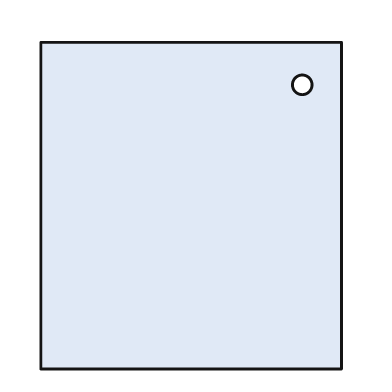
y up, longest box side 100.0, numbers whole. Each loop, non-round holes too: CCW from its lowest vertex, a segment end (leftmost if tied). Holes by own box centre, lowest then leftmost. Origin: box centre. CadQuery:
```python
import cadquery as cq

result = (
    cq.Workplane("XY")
    .moveTo(-46.0, -50.0)
    .lineTo(46.0, -50.0)
    .lineTo(46.0, 50.0)
    .lineTo(-46.0, 50.0)
    .close()
    .moveTo(34.0, 37.0)
    .circle(3.0)
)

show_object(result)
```